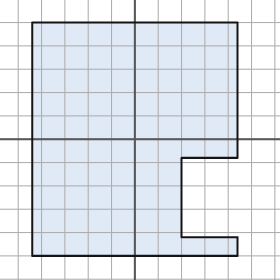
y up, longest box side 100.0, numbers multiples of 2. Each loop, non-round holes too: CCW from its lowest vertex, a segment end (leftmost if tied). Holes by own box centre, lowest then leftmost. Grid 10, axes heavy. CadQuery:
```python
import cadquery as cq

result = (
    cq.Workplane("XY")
    .moveTo(-44.0, -50.0)
    .lineTo(44.0, -50.0)
    .lineTo(44.0, -42.0)
    .lineTo(20.0, -42.0)
    .lineTo(20.0, -8.0)
    .lineTo(44.0, -8.0)
    .lineTo(44.0, 50.0)
    .lineTo(-44.0, 50.0)
    .close()
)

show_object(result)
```